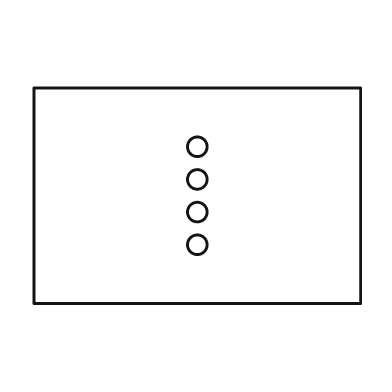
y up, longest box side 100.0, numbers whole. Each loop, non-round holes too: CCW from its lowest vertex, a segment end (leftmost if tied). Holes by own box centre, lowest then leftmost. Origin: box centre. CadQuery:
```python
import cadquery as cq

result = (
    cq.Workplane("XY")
    .moveTo(-50.0, -33.0)
    .lineTo(50.0, -33.0)
    .lineTo(50.0, 33.0)
    .lineTo(-50.0, 33.0)
    .close()
    .moveTo(0.0, -15.0)
    .circle(3.0)
    .moveTo(0.0, -5.0)
    .circle(3.0)
    .moveTo(0.0, 5.0)
    .circle(3.0)
    .moveTo(0.0, 15.0)
    .circle(3.0)
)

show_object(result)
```